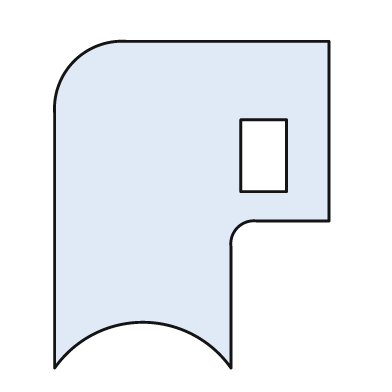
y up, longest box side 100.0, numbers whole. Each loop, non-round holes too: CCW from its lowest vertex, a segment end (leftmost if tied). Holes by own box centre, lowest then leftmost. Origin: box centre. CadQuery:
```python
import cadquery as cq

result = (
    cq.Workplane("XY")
    .moveTo(-42.0, -50.0)
    .threePointArc((-15.0, -36.0), (12.0, -50.0))
    .lineTo(12.0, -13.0)
    .threePointArc((14.0, -7.0), (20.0, -5.0))
    .lineTo(42.0, -5.0)
    .lineTo(42.0, 50.0)
    .lineTo(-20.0, 50.0)
    .threePointArc((-36.0, 44.0), (-42.0, 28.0))
    .close()
    .moveTo(15.0, 4.0)
    .lineTo(29.0, 4.0)
    .lineTo(29.0, 26.0)
    .lineTo(15.0, 26.0)
    .close()
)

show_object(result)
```